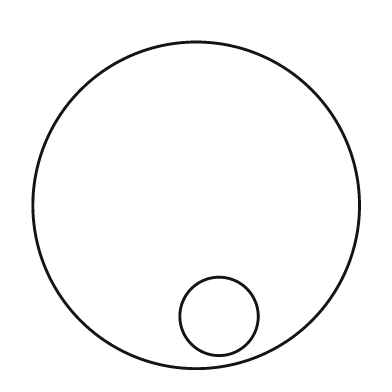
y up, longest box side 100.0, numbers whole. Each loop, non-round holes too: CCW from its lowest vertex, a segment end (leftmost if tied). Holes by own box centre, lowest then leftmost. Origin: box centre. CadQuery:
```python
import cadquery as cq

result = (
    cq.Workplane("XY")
    .moveTo(0.0, 0.0)
    .circle(50.0)
    .moveTo(7.0, -34.0)
    .circle(12.0)
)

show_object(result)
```